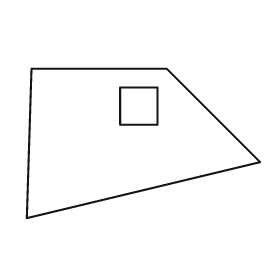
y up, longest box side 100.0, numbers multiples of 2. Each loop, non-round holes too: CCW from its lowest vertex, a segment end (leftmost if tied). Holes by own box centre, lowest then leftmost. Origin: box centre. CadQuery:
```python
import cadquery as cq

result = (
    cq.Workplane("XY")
    .moveTo(-50.0, -32.0)
    .lineTo(50.0, -8.0)
    .lineTo(10.0, 32.0)
    .lineTo(-48.0, 32.0)
    .close()
    .moveTo(-10.0, 8.0)
    .lineTo(6.0, 8.0)
    .lineTo(6.0, 24.0)
    .lineTo(-10.0, 24.0)
    .close()
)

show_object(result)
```